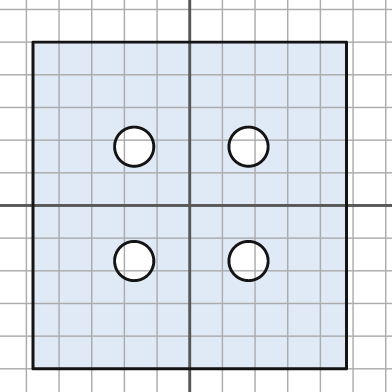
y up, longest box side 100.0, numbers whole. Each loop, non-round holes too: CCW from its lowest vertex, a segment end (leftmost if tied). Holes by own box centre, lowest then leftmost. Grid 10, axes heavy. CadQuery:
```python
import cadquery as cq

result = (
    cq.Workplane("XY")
    .moveTo(-48.0, -50.0)
    .lineTo(48.0, -50.0)
    .lineTo(48.0, 50.0)
    .lineTo(-48.0, 50.0)
    .close()
    .moveTo(-17.0, -17.0)
    .circle(6.0)
    .moveTo(18.0, -17.0)
    .circle(6.0)
    .moveTo(-17.0, 18.0)
    .circle(6.0)
    .moveTo(18.0, 18.0)
    .circle(6.0)
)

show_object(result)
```